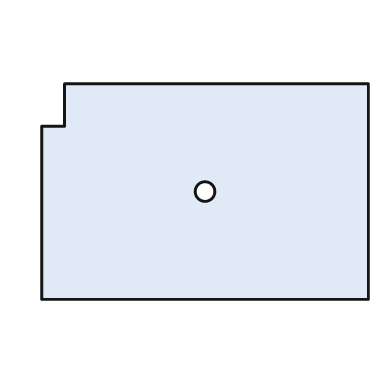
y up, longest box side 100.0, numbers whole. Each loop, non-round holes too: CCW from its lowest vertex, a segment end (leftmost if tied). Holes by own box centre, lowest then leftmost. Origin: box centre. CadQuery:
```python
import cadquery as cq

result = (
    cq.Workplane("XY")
    .moveTo(-50.0, -33.0)
    .lineTo(50.0, -33.0)
    .lineTo(50.0, 33.0)
    .lineTo(-43.0, 33.0)
    .lineTo(-43.0, 20.0)
    .lineTo(-50.0, 20.0)
    .close()
    .moveTo(0.0, 0.0)
    .circle(3.0)
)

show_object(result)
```